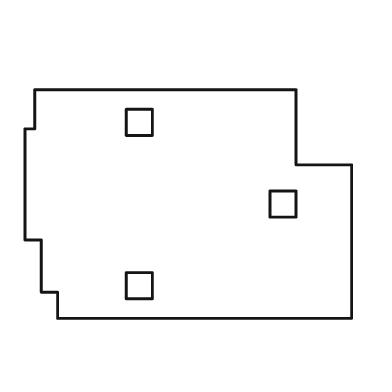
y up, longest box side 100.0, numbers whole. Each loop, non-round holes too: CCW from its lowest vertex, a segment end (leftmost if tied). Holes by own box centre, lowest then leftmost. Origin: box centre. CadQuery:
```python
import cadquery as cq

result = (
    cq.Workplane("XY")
    .moveTo(-40.0, -35.0)
    .lineTo(50.0, -35.0)
    .lineTo(50.0, 12.0)
    .lineTo(33.0, 12.0)
    .lineTo(33.0, 35.0)
    .lineTo(-47.0, 35.0)
    .lineTo(-47.0, 23.0)
    .lineTo(-50.0, 23.0)
    .lineTo(-50.0, -11.0)
    .lineTo(-45.0, -11.0)
    .lineTo(-45.0, -27.0)
    .lineTo(-40.0, -27.0)
    .close()
    .moveTo(-19.0, -29.0)
    .lineTo(-11.0, -29.0)
    .lineTo(-11.0, -21.0)
    .lineTo(-19.0, -21.0)
    .close()
    .moveTo(25.0, -4.0)
    .lineTo(33.0, -4.0)
    .lineTo(33.0, 4.0)
    .lineTo(25.0, 4.0)
    .close()
    .moveTo(-19.0, 21.0)
    .lineTo(-11.0, 21.0)
    .lineTo(-11.0, 29.0)
    .lineTo(-19.0, 29.0)
    .close()
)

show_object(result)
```